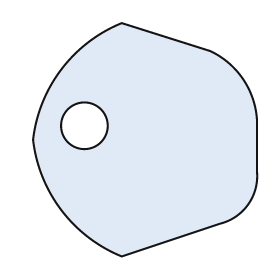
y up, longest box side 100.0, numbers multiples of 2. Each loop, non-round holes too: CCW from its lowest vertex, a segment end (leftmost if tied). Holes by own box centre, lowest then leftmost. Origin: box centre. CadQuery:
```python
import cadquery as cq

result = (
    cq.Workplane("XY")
    .moveTo(-10.0, -50.0)
    .lineTo(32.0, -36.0)
    .threePointArc((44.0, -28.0), (48.0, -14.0))
    .lineTo(48.0, 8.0)
    .threePointArc((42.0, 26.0), (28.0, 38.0))
    .lineTo(-10.0, 50.0)
    .threePointArc((-36.0, 30.0), (-48.0, 0.0))
    .threePointArc((-36.0, -30.0), (-10.0, -50.0))
    .close()
    .moveTo(-26.0, 6.0)
    .circle(10.0)
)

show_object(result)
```